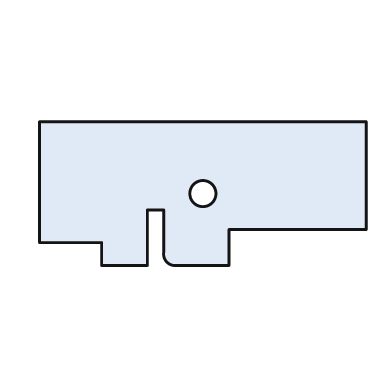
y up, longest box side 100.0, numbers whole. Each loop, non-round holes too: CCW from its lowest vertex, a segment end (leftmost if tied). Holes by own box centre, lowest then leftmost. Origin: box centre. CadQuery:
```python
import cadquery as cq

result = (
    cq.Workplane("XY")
    .moveTo(-31.0, -22.0)
    .lineTo(-17.0, -22.0)
    .lineTo(-17.0, -5.0)
    .lineTo(-12.0, -5.0)
    .lineTo(-12.0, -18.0)
    .threePointArc((-11.0, -21.0), (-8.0, -22.0))
    .lineTo(8.0, -22.0)
    .lineTo(8.0, -11.0)
    .lineTo(50.0, -11.0)
    .lineTo(50.0, 22.0)
    .lineTo(-50.0, 22.0)
    .lineTo(-50.0, -15.0)
    .lineTo(-31.0, -15.0)
    .close()
    .moveTo(0.0, 0.0)
    .circle(4.0)
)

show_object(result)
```